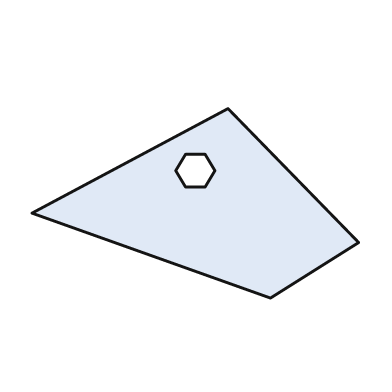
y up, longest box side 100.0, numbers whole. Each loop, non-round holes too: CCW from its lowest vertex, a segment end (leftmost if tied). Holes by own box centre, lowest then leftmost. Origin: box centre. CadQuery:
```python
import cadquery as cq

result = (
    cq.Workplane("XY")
    .moveTo(23.0, -29.0)
    .lineTo(50.0, -12.0)
    .lineTo(10.0, 29.0)
    .lineTo(-50.0, -3.0)
    .close()
    .moveTo(-3.0, 5.0)
    .lineTo(3.0, 5.0)
    .lineTo(6.0, 10.0)
    .lineTo(3.0, 15.0)
    .lineTo(-3.0, 15.0)
    .lineTo(-6.0, 10.0)
    .close()
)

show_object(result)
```